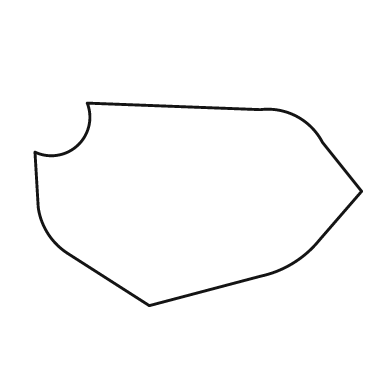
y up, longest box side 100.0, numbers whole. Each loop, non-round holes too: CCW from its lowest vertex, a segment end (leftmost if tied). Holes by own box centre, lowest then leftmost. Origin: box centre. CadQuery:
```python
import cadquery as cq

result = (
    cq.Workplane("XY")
    .moveTo(-15.0, -31.0)
    .lineTo(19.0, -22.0)
    .threePointArc((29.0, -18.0), (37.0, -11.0))
    .lineTo(50.0, 4.0)
    .lineTo(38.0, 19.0)
    .threePointArc((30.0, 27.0), (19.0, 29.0))
    .lineTo(-34.0, 31.0)
    .threePointArc((-37.0, 18.0), (-50.0, 16.0))
    .lineTo(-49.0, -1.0)
    .threePointArc((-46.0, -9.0), (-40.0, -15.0))
    .close()
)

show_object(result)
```